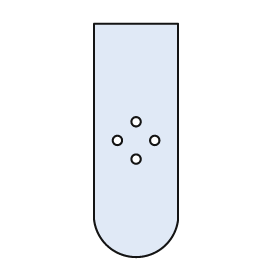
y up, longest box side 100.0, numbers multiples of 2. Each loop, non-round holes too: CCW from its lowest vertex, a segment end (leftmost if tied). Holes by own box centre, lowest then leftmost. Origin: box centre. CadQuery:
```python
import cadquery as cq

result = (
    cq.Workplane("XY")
    .moveTo(-18.0, -34.0)
    .threePointArc((0.0, -50.0), (18.0, -34.0))
    .lineTo(18.0, 50.0)
    .lineTo(-18.0, 50.0)
    .close()
    .moveTo(0.0, -8.0)
    .circle(2.0)
    .moveTo(-8.0, 0.0)
    .circle(2.0)
    .moveTo(8.0, 0.0)
    .circle(2.0)
    .moveTo(0.0, 8.0)
    .circle(2.0)
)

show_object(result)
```